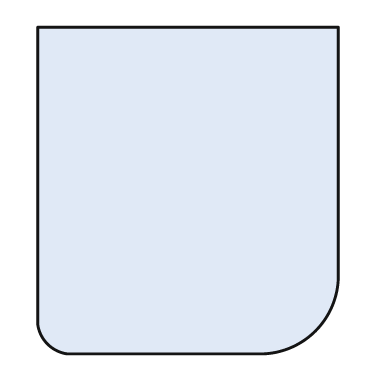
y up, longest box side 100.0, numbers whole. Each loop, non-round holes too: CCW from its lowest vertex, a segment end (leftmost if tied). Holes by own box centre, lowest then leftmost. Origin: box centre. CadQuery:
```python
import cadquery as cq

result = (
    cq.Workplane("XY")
    .moveTo(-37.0, -50.0)
    .lineTo(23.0, -50.0)
    .threePointArc((39.0, -43.0), (46.0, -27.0))
    .lineTo(46.0, 50.0)
    .lineTo(-46.0, 50.0)
    .lineTo(-46.0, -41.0)
    .threePointArc((-43.0, -47.0), (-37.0, -50.0))
    .close()
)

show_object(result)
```